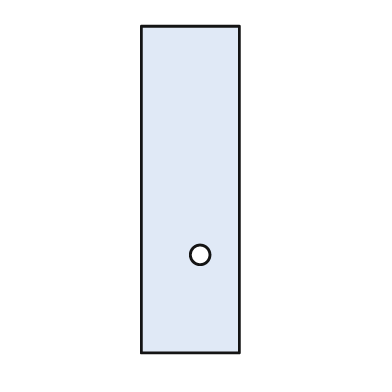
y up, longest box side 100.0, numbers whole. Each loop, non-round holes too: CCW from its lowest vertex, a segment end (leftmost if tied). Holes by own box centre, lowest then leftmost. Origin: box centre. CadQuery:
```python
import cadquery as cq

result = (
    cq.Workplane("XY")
    .moveTo(-15.0, -50.0)
    .lineTo(15.0, -50.0)
    .lineTo(15.0, 50.0)
    .lineTo(-15.0, 50.0)
    .close()
    .moveTo(3.0, -20.0)
    .circle(3.0)
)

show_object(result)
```